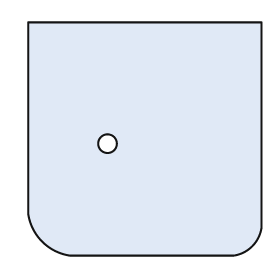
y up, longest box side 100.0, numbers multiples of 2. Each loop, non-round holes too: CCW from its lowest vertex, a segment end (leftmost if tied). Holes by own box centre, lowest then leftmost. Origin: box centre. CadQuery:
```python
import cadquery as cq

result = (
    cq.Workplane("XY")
    .moveTo(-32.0, -50.0)
    .lineTo(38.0, -50.0)
    .threePointArc((46.0, -46.0), (50.0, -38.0))
    .lineTo(50.0, 50.0)
    .lineTo(-50.0, 50.0)
    .lineTo(-50.0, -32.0)
    .threePointArc((-44.0, -44.0), (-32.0, -50.0))
    .close()
    .moveTo(-16.0, -2.0)
    .circle(4.0)
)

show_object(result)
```